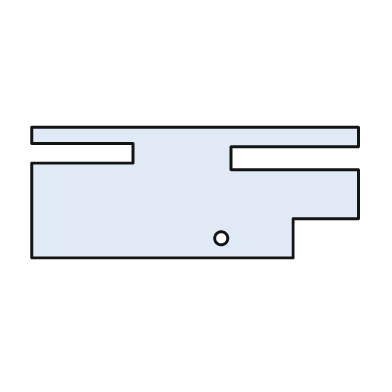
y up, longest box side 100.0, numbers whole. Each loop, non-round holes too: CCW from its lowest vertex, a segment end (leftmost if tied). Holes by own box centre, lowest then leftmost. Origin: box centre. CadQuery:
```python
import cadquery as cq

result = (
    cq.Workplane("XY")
    .moveTo(-50.0, -20.0)
    .lineTo(30.0, -20.0)
    .lineTo(30.0, -8.0)
    .lineTo(50.0, -8.0)
    .lineTo(50.0, 7.0)
    .lineTo(11.0, 7.0)
    .lineTo(11.0, 14.0)
    .lineTo(50.0, 14.0)
    .lineTo(50.0, 20.0)
    .lineTo(-50.0, 20.0)
    .lineTo(-50.0, 15.0)
    .lineTo(-19.0, 15.0)
    .lineTo(-19.0, 9.0)
    .lineTo(-50.0, 9.0)
    .close()
    .moveTo(8.0, -14.0)
    .circle(2.0)
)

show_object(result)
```